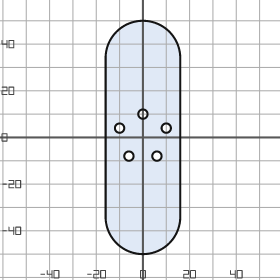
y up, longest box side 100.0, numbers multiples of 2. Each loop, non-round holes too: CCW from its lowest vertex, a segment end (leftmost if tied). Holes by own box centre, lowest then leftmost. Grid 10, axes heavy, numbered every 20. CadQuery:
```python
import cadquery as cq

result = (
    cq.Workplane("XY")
    .moveTo(-16.0, -34.0)
    .threePointArc((0.0, -50.0), (16.0, -34.0))
    .lineTo(16.0, 34.0)
    .threePointArc((0.0, 50.0), (-16.0, 34.0))
    .close()
    .moveTo(-6.0, -8.0)
    .circle(2.0)
    .moveTo(6.0, -8.0)
    .circle(2.0)
    .moveTo(-10.0, 4.0)
    .circle(2.0)
    .moveTo(10.0, 4.0)
    .circle(2.0)
    .moveTo(0.0, 10.0)
    .circle(2.0)
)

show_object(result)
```